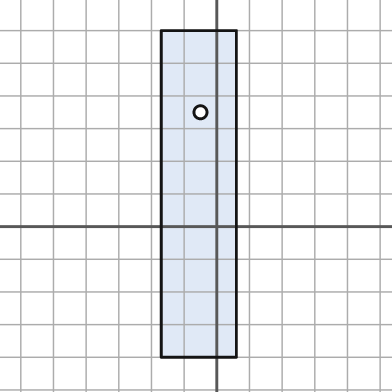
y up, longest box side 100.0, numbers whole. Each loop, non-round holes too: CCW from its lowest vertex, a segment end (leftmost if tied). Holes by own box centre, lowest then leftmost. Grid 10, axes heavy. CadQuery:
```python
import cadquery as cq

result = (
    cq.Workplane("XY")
    .moveTo(-17.0, -40.0)
    .lineTo(6.0, -40.0)
    .lineTo(6.0, 60.0)
    .lineTo(-17.0, 60.0)
    .close()
    .moveTo(-5.0, 35.0)
    .circle(2.0)
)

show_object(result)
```